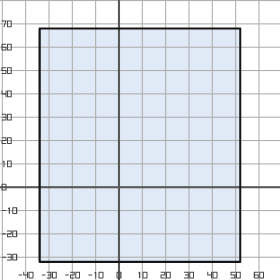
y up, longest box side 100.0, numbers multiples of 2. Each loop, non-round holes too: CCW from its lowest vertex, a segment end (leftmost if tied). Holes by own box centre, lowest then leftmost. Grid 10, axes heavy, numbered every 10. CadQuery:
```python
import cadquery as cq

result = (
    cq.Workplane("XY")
    .moveTo(-34.0, -32.0)
    .lineTo(52.0, -32.0)
    .lineTo(52.0, 68.0)
    .lineTo(-34.0, 68.0)
    .close()
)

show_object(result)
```